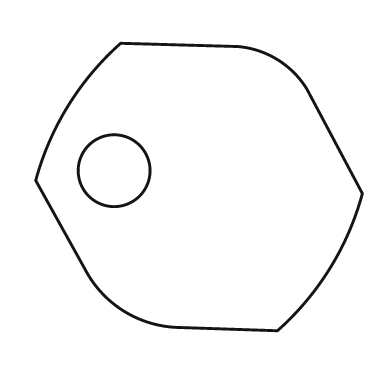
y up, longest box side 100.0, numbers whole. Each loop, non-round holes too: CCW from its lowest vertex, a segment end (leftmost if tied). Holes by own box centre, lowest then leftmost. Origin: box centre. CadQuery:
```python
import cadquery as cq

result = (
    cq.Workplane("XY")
    .moveTo(24.0, -44.0)
    .threePointArc((40.0, -25.0), (50.0, -2.0))
    .lineTo(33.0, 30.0)
    .threePointArc((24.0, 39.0), (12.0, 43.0))
    .lineTo(-24.0, 44.0)
    .threePointArc((-40.0, 25.0), (-50.0, 2.0))
    .lineTo(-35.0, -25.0)
    .threePointArc((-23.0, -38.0), (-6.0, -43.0))
    .close()
    .moveTo(-26.0, 5.0)
    .circle(11.0)
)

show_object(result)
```